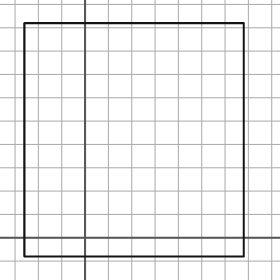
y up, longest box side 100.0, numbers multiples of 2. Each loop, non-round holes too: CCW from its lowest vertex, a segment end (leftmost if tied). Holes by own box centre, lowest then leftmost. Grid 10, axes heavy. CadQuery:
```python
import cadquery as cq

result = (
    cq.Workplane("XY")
    .moveTo(-26.0, -8.0)
    .lineTo(68.0, -8.0)
    .lineTo(68.0, 92.0)
    .lineTo(-26.0, 92.0)
    .close()
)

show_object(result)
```